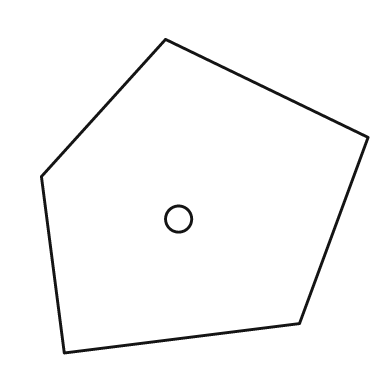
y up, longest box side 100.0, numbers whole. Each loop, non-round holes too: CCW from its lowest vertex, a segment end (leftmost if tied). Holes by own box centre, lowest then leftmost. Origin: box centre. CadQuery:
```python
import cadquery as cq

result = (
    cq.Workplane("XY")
    .moveTo(-43.0, -48.0)
    .lineTo(29.0, -39.0)
    .lineTo(50.0, 18.0)
    .lineTo(-12.0, 48.0)
    .lineTo(-50.0, 6.0)
    .close()
    .moveTo(-8.0, -7.0)
    .circle(4.0)
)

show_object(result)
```